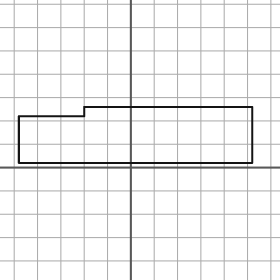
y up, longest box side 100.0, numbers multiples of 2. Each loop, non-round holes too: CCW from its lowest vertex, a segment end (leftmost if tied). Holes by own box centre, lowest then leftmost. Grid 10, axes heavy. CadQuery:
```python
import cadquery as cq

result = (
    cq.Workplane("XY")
    .moveTo(-48.0, 2.0)
    .lineTo(52.0, 2.0)
    .lineTo(52.0, 26.0)
    .lineTo(-20.0, 26.0)
    .lineTo(-20.0, 22.0)
    .lineTo(-48.0, 22.0)
    .close()
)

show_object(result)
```